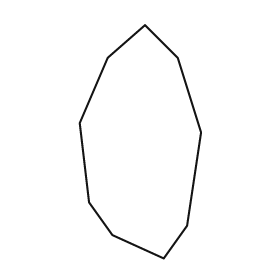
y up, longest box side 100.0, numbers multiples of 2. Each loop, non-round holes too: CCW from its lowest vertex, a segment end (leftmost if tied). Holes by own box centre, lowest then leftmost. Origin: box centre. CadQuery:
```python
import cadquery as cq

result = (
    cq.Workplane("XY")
    .moveTo(10.0, -50.0)
    .lineTo(20.0, -36.0)
    .lineTo(26.0, 4.0)
    .lineTo(16.0, 36.0)
    .lineTo(2.0, 50.0)
    .lineTo(-14.0, 36.0)
    .lineTo(-26.0, 8.0)
    .lineTo(-22.0, -26.0)
    .lineTo(-12.0, -40.0)
    .close()
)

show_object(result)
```